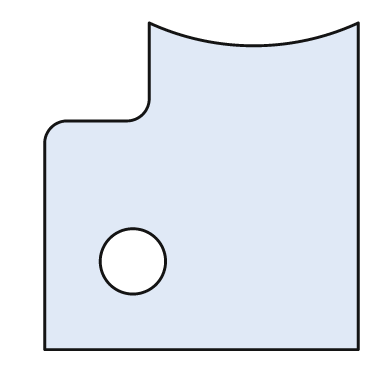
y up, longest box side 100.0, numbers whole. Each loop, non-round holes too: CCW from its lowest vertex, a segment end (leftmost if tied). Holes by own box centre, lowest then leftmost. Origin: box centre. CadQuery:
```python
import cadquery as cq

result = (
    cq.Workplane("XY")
    .moveTo(-48.0, -50.0)
    .lineTo(48.0, -50.0)
    .lineTo(48.0, 50.0)
    .threePointArc((16.0, 43.0), (-16.0, 50.0))
    .lineTo(-16.0, 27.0)
    .threePointArc((-18.0, 22.0), (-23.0, 20.0))
    .lineTo(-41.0, 20.0)
    .threePointArc((-46.0, 18.0), (-48.0, 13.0))
    .close()
    .moveTo(-21.0, -23.0)
    .circle(10.0)
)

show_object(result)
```